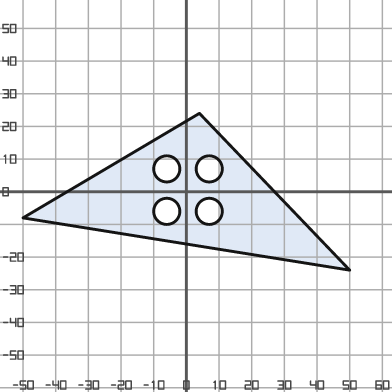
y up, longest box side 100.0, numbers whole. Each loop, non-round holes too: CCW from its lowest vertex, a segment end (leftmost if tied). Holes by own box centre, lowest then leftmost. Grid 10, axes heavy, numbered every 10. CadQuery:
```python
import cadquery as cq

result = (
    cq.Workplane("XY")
    .moveTo(50.0, -24.0)
    .lineTo(4.0, 24.0)
    .lineTo(-50.0, -8.0)
    .close()
    .moveTo(-6.0, -6.0)
    .circle(4.0)
    .moveTo(7.0, -6.0)
    .circle(4.0)
    .moveTo(-6.0, 7.0)
    .circle(4.0)
    .moveTo(7.0, 7.0)
    .circle(4.0)
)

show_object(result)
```